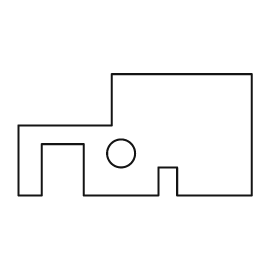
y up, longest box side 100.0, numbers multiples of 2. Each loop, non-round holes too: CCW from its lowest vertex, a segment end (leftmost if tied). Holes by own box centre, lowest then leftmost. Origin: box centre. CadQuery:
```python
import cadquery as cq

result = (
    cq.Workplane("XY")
    .moveTo(-50.0, -26.0)
    .lineTo(-40.0, -26.0)
    .lineTo(-40.0, -4.0)
    .lineTo(-22.0, -4.0)
    .lineTo(-22.0, -26.0)
    .lineTo(10.0, -26.0)
    .lineTo(10.0, -14.0)
    .lineTo(18.0, -14.0)
    .lineTo(18.0, -26.0)
    .lineTo(50.0, -26.0)
    .lineTo(50.0, 26.0)
    .lineTo(-10.0, 26.0)
    .lineTo(-10.0, 4.0)
    .lineTo(-50.0, 4.0)
    .close()
    .moveTo(-6.0, -8.0)
    .circle(6.0)
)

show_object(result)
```